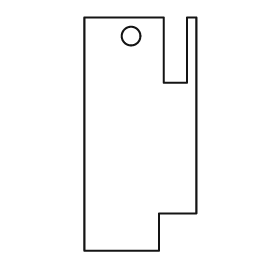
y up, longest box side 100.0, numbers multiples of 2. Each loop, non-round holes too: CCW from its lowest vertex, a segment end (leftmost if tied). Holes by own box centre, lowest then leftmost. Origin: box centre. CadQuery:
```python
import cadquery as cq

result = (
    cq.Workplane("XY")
    .moveTo(-24.0, -50.0)
    .lineTo(8.0, -50.0)
    .lineTo(8.0, -34.0)
    .lineTo(24.0, -34.0)
    .lineTo(24.0, 50.0)
    .lineTo(20.0, 50.0)
    .lineTo(20.0, 22.0)
    .lineTo(10.0, 22.0)
    .lineTo(10.0, 50.0)
    .lineTo(-24.0, 50.0)
    .close()
    .moveTo(-4.0, 42.0)
    .circle(4.0)
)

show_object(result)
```